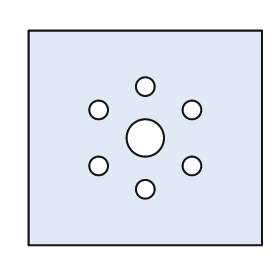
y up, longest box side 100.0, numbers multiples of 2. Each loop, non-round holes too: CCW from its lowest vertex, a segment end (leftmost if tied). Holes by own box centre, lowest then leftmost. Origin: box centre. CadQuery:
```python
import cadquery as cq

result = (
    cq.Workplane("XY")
    .moveTo(-50.0, -46.0)
    .lineTo(50.0, -46.0)
    .lineTo(50.0, 46.0)
    .lineTo(-50.0, 46.0)
    .close()
    .moveTo(0.0, -22.0)
    .circle(4.0)
    .moveTo(-20.0, -12.0)
    .circle(4.0)
    .moveTo(20.0, -12.0)
    .circle(4.0)
    .moveTo(0.0, 0.0)
    .circle(8.0)
    .moveTo(-20.0, 12.0)
    .circle(4.0)
    .moveTo(20.0, 12.0)
    .circle(4.0)
    .moveTo(0.0, 22.0)
    .circle(4.0)
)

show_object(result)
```